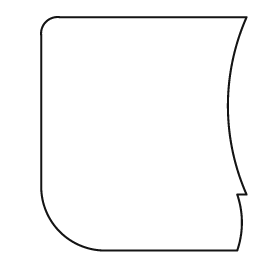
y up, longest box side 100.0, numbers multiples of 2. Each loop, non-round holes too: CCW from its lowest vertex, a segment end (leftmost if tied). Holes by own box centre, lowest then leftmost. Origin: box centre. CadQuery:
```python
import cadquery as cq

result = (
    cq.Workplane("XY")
    .moveTo(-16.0, -50.0)
    .lineTo(40.0, -50.0)
    .threePointArc((42.0, -38.0), (40.0, -26.0))
    .lineTo(44.0, -26.0)
    .threePointArc((36.0, 12.0), (44.0, 50.0))
    .lineTo(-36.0, 50.0)
    .threePointArc((-42.0, 48.0), (-44.0, 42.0))
    .lineTo(-44.0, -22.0)
    .threePointArc((-36.0, -42.0), (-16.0, -50.0))
    .close()
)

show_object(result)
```